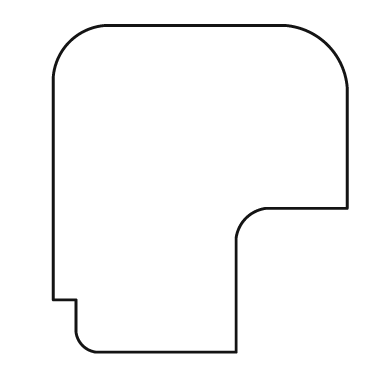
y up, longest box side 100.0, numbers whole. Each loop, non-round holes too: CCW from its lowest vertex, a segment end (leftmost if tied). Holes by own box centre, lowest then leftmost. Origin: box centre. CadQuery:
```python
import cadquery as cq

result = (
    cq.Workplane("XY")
    .moveTo(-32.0, -50.0)
    .lineTo(11.0, -50.0)
    .lineTo(11.0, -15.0)
    .threePointArc((14.0, -9.0), (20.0, -6.0))
    .lineTo(45.0, -6.0)
    .lineTo(45.0, 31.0)
    .threePointArc((39.0, 44.0), (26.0, 50.0))
    .lineTo(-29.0, 50.0)
    .threePointArc((-40.0, 45.0), (-45.0, 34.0))
    .lineTo(-45.0, -34.0)
    .lineTo(-38.0, -34.0)
    .lineTo(-38.0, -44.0)
    .threePointArc((-36.0, -48.0), (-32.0, -50.0))
    .close()
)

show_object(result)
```